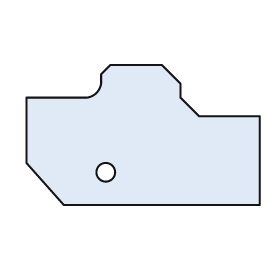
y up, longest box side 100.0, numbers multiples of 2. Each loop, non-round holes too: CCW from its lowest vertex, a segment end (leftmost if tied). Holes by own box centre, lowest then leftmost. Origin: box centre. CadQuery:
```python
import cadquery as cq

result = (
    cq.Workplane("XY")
    .moveTo(-34.0, -30.0)
    .lineTo(50.0, -30.0)
    .lineTo(50.0, 8.0)
    .lineTo(24.0, 8.0)
    .lineTo(16.0, 16.0)
    .lineTo(16.0, 22.0)
    .lineTo(8.0, 30.0)
    .lineTo(-14.0, 30.0)
    .lineTo(-18.0, 26.0)
    .lineTo(-18.0, 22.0)
    .threePointArc((-20.0, 18.0), (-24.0, 16.0))
    .lineTo(-50.0, 16.0)
    .lineTo(-50.0, -12.0)
    .close()
    .moveTo(-16.0, -16.0)
    .circle(4.0)
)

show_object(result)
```